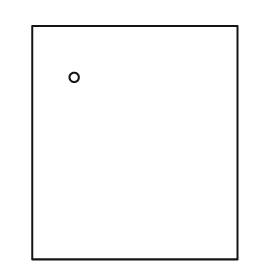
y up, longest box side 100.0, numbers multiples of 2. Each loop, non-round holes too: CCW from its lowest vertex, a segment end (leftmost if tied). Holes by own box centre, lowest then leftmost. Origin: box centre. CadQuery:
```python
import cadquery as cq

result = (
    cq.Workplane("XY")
    .moveTo(-44.0, -50.0)
    .lineTo(44.0, -50.0)
    .lineTo(44.0, 50.0)
    .lineTo(-44.0, 50.0)
    .close()
    .moveTo(-26.0, 28.0)
    .circle(2.0)
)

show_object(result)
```